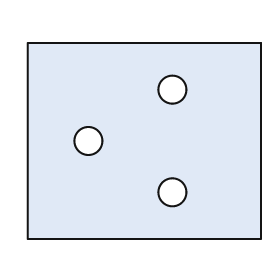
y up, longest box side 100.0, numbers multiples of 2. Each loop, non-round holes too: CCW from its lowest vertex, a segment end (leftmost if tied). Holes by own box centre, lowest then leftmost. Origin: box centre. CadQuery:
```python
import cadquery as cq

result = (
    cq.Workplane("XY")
    .moveTo(-50.0, -42.0)
    .lineTo(50.0, -42.0)
    .lineTo(50.0, 42.0)
    .lineTo(-50.0, 42.0)
    .close()
    .moveTo(12.0, -22.0)
    .circle(6.0)
    .moveTo(-24.0, 0.0)
    .circle(6.0)
    .moveTo(12.0, 22.0)
    .circle(6.0)
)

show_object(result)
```